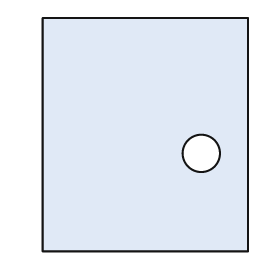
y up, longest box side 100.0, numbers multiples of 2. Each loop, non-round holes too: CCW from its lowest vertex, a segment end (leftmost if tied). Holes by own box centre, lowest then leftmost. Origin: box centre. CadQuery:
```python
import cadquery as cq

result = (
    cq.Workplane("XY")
    .moveTo(-44.0, -50.0)
    .lineTo(44.0, -50.0)
    .lineTo(44.0, 50.0)
    .lineTo(-44.0, 50.0)
    .close()
    .moveTo(24.0, -8.0)
    .circle(8.0)
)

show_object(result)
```